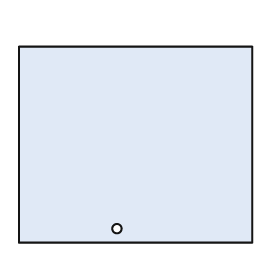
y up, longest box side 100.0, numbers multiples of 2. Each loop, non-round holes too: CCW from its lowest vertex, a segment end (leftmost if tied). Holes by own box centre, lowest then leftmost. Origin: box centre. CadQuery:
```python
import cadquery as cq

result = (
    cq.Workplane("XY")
    .moveTo(-50.0, -42.0)
    .lineTo(50.0, -42.0)
    .lineTo(50.0, 42.0)
    .lineTo(-50.0, 42.0)
    .close()
    .moveTo(-8.0, -36.0)
    .circle(2.0)
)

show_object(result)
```